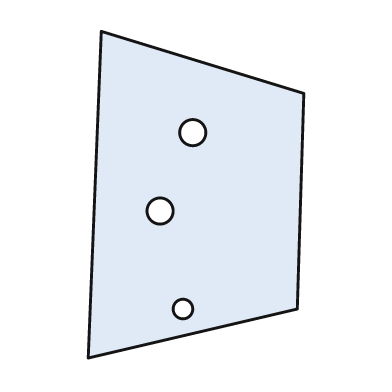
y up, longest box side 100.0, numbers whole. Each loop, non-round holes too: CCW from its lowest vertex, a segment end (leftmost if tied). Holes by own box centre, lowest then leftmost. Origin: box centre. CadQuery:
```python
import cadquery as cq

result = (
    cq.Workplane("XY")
    .moveTo(-33.0, -50.0)
    .lineTo(31.0, -35.0)
    .lineTo(33.0, 31.0)
    .lineTo(-29.0, 50.0)
    .close()
    .moveTo(-4.0, -35.0)
    .circle(3.0)
    .moveTo(-11.0, -5.0)
    .circle(4.0)
    .moveTo(-1.0, 19.0)
    .circle(4.0)
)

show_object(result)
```